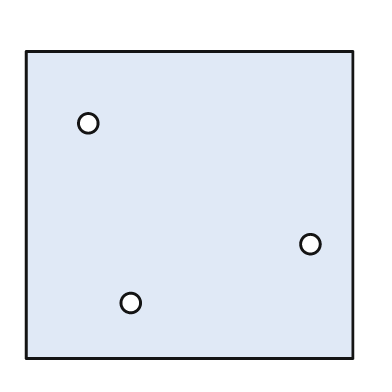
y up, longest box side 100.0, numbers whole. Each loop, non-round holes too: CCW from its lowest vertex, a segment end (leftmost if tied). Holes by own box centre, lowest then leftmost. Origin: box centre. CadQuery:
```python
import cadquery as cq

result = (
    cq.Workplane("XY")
    .moveTo(-50.0, -47.0)
    .lineTo(50.0, -47.0)
    .lineTo(50.0, 47.0)
    .lineTo(-50.0, 47.0)
    .close()
    .moveTo(-18.0, -30.0)
    .circle(3.0)
    .moveTo(37.0, -12.0)
    .circle(3.0)
    .moveTo(-31.0, 25.0)
    .circle(3.0)
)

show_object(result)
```